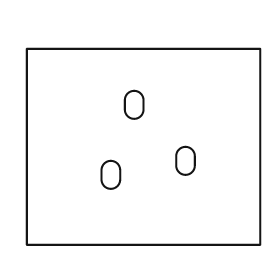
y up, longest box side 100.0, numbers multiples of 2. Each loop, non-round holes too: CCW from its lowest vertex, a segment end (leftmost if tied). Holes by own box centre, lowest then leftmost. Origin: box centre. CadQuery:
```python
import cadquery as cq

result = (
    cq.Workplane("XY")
    .moveTo(-50.0, -42.0)
    .lineTo(50.0, -42.0)
    .lineTo(50.0, 42.0)
    .lineTo(-50.0, 42.0)
    .close()
    .moveTo(-18.0, -14.0)
    .threePointArc((-14.0, -18.0), (-10.0, -14.0))
    .lineTo(-10.0, -10.0)
    .threePointArc((-14.0, -6.0), (-18.0, -10.0))
    .close()
    .moveTo(14.0, -8.0)
    .threePointArc((18.0, -12.0), (22.0, -8.0))
    .lineTo(22.0, -4.0)
    .threePointArc((18.0, 0.0), (14.0, -4.0))
    .close()
    .moveTo(-8.0, 16.0)
    .threePointArc((-4.0, 12.0), (0.0, 16.0))
    .lineTo(0.0, 20.0)
    .threePointArc((-4.0, 24.0), (-8.0, 20.0))
    .close()
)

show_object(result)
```